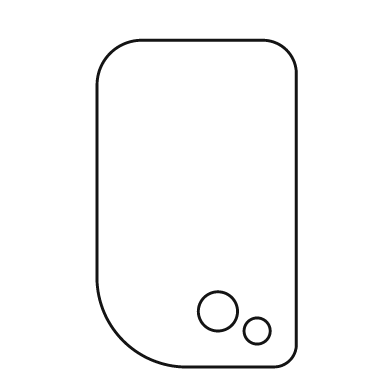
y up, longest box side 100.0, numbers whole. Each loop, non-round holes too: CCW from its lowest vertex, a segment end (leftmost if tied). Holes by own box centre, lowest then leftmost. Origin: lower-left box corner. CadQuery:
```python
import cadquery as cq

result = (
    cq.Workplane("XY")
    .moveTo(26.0, 0.0)
    .lineTo(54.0, 0.0)
    .threePointArc((59.0, 2.0), (61.0, 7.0))
    .lineTo(61.0, 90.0)
    .threePointArc((58.0, 97.0), (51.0, 100.0))
    .lineTo(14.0, 100.0)
    .threePointArc((4.0, 96.0), (0.0, 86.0))
    .lineTo(0.0, 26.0)
    .threePointArc((8.0, 8.0), (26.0, 0.0))
    .close()
    .moveTo(49.0, 11.0)
    .circle(4.0)
    .moveTo(37.0, 17.0)
    .circle(6.0)
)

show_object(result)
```